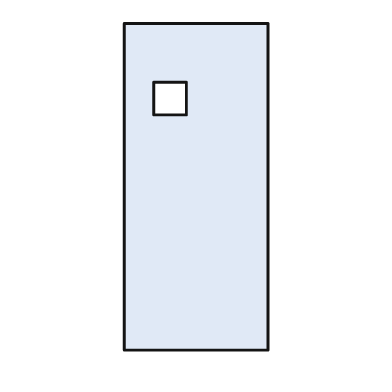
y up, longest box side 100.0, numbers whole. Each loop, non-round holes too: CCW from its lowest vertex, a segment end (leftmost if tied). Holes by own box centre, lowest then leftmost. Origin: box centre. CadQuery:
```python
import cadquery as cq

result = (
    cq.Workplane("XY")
    .moveTo(-22.0, -50.0)
    .lineTo(22.0, -50.0)
    .lineTo(22.0, 50.0)
    .lineTo(-22.0, 50.0)
    .close()
    .moveTo(-13.0, 22.0)
    .lineTo(-3.0, 22.0)
    .lineTo(-3.0, 32.0)
    .lineTo(-13.0, 32.0)
    .close()
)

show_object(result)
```